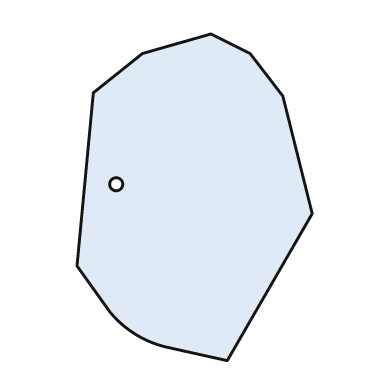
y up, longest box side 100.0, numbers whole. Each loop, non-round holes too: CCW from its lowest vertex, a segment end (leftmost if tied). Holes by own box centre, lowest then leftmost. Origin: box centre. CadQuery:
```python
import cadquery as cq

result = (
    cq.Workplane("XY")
    .moveTo(10.0, -50.0)
    .lineTo(36.0, -5.0)
    .lineTo(27.0, 31.0)
    .lineTo(17.0, 44.0)
    .lineTo(5.0, 50.0)
    .lineTo(-16.0, 44.0)
    .lineTo(-31.0, 32.0)
    .lineTo(-36.0, -21.0)
    .lineTo(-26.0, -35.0)
    .threePointArc((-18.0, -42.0), (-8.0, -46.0))
    .close()
    .moveTo(-24.0, 4.0)
    .circle(2.0)
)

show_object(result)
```